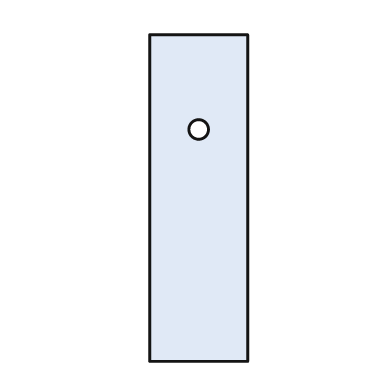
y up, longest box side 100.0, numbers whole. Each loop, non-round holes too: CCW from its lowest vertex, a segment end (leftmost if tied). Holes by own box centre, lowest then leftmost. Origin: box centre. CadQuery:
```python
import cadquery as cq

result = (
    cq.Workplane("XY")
    .moveTo(-15.0, -50.0)
    .lineTo(15.0, -50.0)
    .lineTo(15.0, 50.0)
    .lineTo(-15.0, 50.0)
    .close()
    .moveTo(0.0, 21.0)
    .circle(3.0)
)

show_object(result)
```